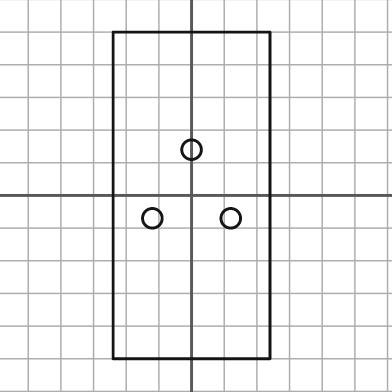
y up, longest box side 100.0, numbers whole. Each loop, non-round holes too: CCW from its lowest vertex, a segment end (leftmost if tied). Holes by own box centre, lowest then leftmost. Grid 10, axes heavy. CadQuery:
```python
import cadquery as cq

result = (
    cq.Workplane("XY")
    .moveTo(-24.0, -50.0)
    .lineTo(24.0, -50.0)
    .lineTo(24.0, 50.0)
    .lineTo(-24.0, 50.0)
    .close()
    .moveTo(-12.0, -7.0)
    .circle(3.0)
    .moveTo(12.0, -7.0)
    .circle(3.0)
    .moveTo(0.0, 14.0)
    .circle(3.0)
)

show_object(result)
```